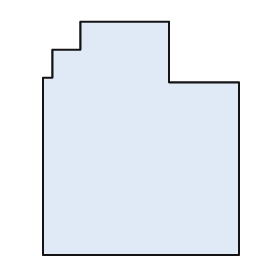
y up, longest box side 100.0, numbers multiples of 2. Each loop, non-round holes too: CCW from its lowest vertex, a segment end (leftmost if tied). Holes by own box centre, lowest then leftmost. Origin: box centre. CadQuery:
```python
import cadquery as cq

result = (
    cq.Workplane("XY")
    .moveTo(-42.0, -50.0)
    .lineTo(42.0, -50.0)
    .lineTo(42.0, 24.0)
    .lineTo(12.0, 24.0)
    .lineTo(12.0, 50.0)
    .lineTo(-26.0, 50.0)
    .lineTo(-26.0, 38.0)
    .lineTo(-38.0, 38.0)
    .lineTo(-38.0, 26.0)
    .lineTo(-42.0, 26.0)
    .close()
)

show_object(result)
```